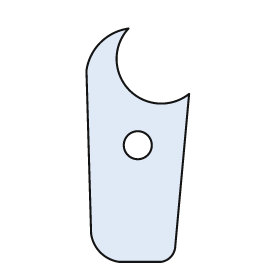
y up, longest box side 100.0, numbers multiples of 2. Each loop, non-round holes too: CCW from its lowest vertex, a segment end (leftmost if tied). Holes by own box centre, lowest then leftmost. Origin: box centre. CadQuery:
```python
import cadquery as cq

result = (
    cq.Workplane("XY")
    .moveTo(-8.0, -50.0)
    .lineTo(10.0, -50.0)
    .threePointArc((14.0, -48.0), (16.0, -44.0))
    .lineTo(22.0, 22.0)
    .threePointArc((-4.0, 24.0), (-4.0, 50.0))
    .threePointArc((-16.0, 44.0), (-22.0, 32.0))
    .lineTo(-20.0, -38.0)
    .threePointArc((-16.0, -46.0), (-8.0, -50.0))
    .close()
    .moveTo(0.0, 0.0)
    .circle(6.0)
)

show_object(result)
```